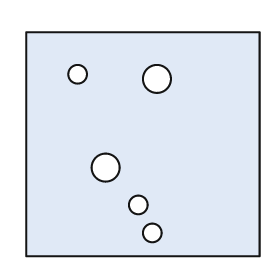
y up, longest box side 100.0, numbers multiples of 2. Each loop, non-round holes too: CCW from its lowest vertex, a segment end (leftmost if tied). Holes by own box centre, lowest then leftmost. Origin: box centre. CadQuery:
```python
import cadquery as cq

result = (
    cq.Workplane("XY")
    .moveTo(-50.0, -48.0)
    .lineTo(50.0, -48.0)
    .lineTo(50.0, 48.0)
    .lineTo(-50.0, 48.0)
    .close()
    .moveTo(4.0, -38.0)
    .circle(4.0)
    .moveTo(-2.0, -26.0)
    .circle(4.0)
    .moveTo(-16.0, -10.0)
    .circle(6.0)
    .moveTo(6.0, 28.0)
    .circle(6.0)
    .moveTo(-28.0, 30.0)
    .circle(4.0)
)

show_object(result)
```